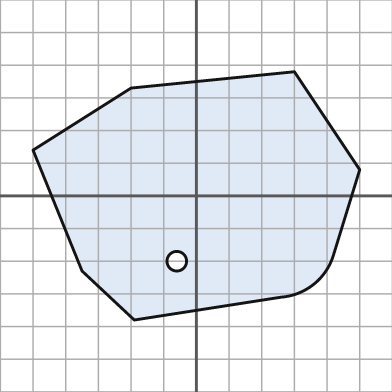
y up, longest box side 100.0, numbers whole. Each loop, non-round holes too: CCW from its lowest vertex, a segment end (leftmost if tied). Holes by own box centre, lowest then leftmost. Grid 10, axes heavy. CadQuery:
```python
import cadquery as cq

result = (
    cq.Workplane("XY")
    .moveTo(-19.0, -38.0)
    .lineTo(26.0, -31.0)
    .threePointArc((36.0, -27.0), (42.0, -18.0))
    .lineTo(50.0, 8.0)
    .lineTo(30.0, 38.0)
    .lineTo(-20.0, 33.0)
    .lineTo(-50.0, 14.0)
    .lineTo(-35.0, -23.0)
    .close()
    .moveTo(-6.0, -20.0)
    .circle(3.0)
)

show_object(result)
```